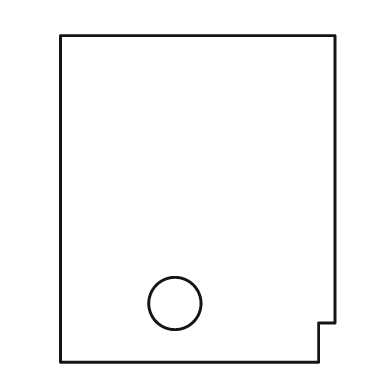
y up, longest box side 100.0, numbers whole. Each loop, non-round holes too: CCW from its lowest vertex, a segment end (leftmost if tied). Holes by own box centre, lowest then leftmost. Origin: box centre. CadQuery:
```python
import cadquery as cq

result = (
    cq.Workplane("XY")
    .moveTo(-42.0, -50.0)
    .lineTo(37.0, -50.0)
    .lineTo(37.0, -38.0)
    .lineTo(42.0, -38.0)
    .lineTo(42.0, 50.0)
    .lineTo(-42.0, 50.0)
    .close()
    .moveTo(-7.0, -32.0)
    .circle(8.0)
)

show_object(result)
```